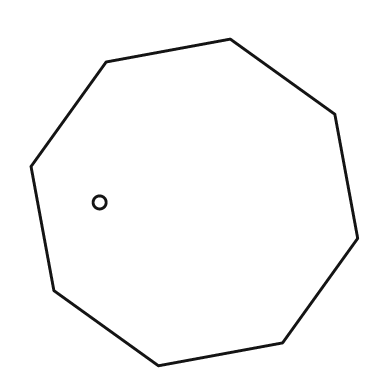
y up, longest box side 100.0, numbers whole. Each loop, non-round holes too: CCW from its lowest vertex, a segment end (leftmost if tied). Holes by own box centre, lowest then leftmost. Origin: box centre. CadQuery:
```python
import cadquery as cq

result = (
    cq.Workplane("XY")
    .moveTo(-11.0, -50.0)
    .lineTo(27.0, -43.0)
    .lineTo(50.0, -11.0)
    .lineTo(43.0, 27.0)
    .lineTo(11.0, 50.0)
    .lineTo(-27.0, 43.0)
    .lineTo(-50.0, 11.0)
    .lineTo(-43.0, -27.0)
    .close()
    .moveTo(-29.0, 0.0)
    .circle(2.0)
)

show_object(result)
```